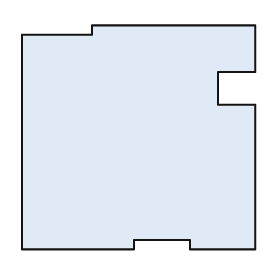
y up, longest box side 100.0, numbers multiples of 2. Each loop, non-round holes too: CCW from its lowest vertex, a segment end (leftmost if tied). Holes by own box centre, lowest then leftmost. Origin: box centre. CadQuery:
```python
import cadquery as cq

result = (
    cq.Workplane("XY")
    .moveTo(-50.0, -48.0)
    .lineTo(-2.0, -48.0)
    .lineTo(-2.0, -44.0)
    .lineTo(22.0, -44.0)
    .lineTo(22.0, -48.0)
    .lineTo(50.0, -48.0)
    .lineTo(50.0, 14.0)
    .lineTo(34.0, 14.0)
    .lineTo(34.0, 28.0)
    .lineTo(50.0, 28.0)
    .lineTo(50.0, 48.0)
    .lineTo(-20.0, 48.0)
    .lineTo(-20.0, 44.0)
    .lineTo(-50.0, 44.0)
    .close()
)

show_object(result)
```